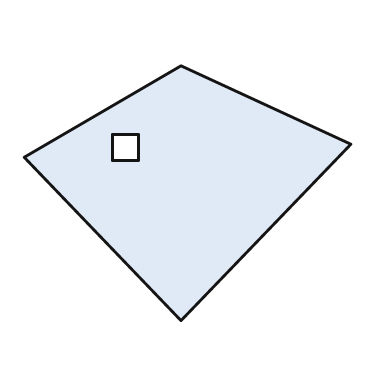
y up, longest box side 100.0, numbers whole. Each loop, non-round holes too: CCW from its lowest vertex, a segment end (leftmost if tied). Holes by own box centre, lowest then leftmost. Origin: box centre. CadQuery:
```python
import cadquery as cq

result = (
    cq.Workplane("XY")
    .moveTo(-2.0, -39.0)
    .lineTo(50.0, 15.0)
    .lineTo(-2.0, 39.0)
    .lineTo(-50.0, 11.0)
    .close()
    .moveTo(-23.0, 10.0)
    .lineTo(-15.0, 10.0)
    .lineTo(-15.0, 18.0)
    .lineTo(-23.0, 18.0)
    .close()
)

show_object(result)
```